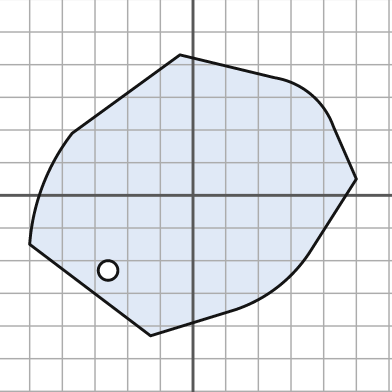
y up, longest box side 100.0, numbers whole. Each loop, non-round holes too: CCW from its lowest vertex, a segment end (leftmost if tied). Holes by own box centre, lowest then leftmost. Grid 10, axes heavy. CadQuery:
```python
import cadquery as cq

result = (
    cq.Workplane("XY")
    .moveTo(-13.0, -43.0)
    .lineTo(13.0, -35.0)
    .threePointArc((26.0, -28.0), (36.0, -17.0))
    .lineTo(50.0, 5.0)
    .lineTo(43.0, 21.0)
    .threePointArc((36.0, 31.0), (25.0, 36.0))
    .lineTo(-4.0, 43.0)
    .lineTo(-37.0, 19.0)
    .threePointArc((-46.0, 3.0), (-50.0, -15.0))
    .close()
    .moveTo(-26.0, -23.0)
    .circle(3.0)
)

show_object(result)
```